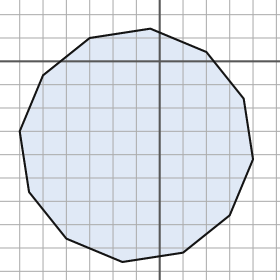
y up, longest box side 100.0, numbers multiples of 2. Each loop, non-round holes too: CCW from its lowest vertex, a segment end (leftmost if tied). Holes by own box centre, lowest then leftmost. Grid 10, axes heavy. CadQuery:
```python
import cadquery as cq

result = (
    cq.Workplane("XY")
    .moveTo(-16.0, -86.0)
    .lineTo(10.0, -82.0)
    .lineTo(30.0, -66.0)
    .lineTo(40.0, -42.0)
    .lineTo(36.0, -16.0)
    .lineTo(20.0, 4.0)
    .lineTo(-4.0, 14.0)
    .lineTo(-30.0, 10.0)
    .lineTo(-50.0, -6.0)
    .lineTo(-60.0, -30.0)
    .lineTo(-56.0, -56.0)
    .lineTo(-40.0, -76.0)
    .close()
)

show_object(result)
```